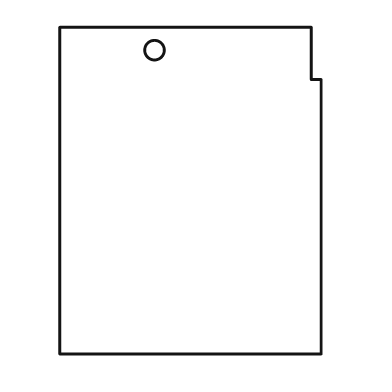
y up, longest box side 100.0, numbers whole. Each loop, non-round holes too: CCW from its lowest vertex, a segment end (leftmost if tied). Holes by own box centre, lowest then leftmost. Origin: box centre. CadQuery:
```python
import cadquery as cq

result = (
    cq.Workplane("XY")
    .moveTo(-40.0, -50.0)
    .lineTo(40.0, -50.0)
    .lineTo(40.0, 34.0)
    .lineTo(37.0, 34.0)
    .lineTo(37.0, 50.0)
    .lineTo(-40.0, 50.0)
    .close()
    .moveTo(-11.0, 43.0)
    .circle(3.0)
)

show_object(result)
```